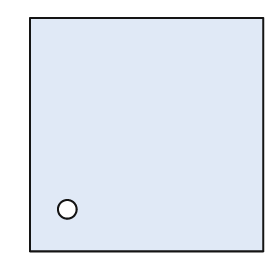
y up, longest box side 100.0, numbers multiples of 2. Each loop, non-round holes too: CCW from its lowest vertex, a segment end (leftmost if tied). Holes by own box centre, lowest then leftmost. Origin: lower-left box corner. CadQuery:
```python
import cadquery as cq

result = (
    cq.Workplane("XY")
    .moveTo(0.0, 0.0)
    .lineTo(100.0, 0.0)
    .lineTo(100.0, 100.0)
    .lineTo(0.0, 100.0)
    .close()
    .moveTo(16.0, 18.0)
    .circle(4.0)
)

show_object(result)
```